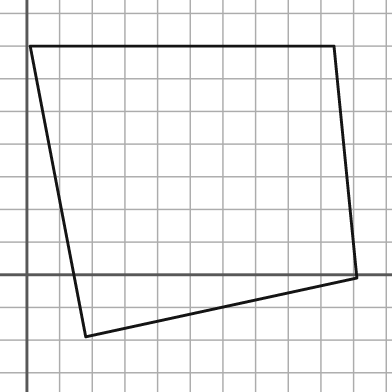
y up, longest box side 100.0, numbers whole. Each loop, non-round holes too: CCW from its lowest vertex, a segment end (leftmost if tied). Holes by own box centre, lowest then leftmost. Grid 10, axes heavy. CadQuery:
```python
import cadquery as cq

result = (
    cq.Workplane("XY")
    .moveTo(18.0, -19.0)
    .lineTo(101.0, -1.0)
    .lineTo(94.0, 70.0)
    .lineTo(1.0, 70.0)
    .close()
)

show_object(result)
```